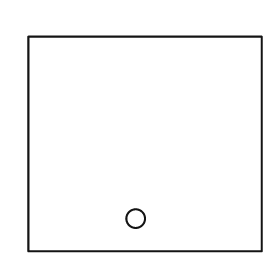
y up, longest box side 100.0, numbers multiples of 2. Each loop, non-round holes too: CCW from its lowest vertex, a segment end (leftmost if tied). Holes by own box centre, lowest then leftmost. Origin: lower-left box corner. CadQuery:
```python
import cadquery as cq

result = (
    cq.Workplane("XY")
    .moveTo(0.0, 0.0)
    .lineTo(100.0, 0.0)
    .lineTo(100.0, 92.0)
    .lineTo(0.0, 92.0)
    .close()
    .moveTo(46.0, 14.0)
    .circle(4.0)
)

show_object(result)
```